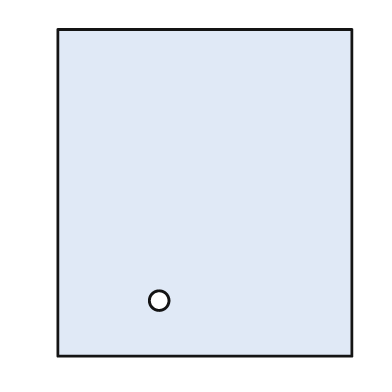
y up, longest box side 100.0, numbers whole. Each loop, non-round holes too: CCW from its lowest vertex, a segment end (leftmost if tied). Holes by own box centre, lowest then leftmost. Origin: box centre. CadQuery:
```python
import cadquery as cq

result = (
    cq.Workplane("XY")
    .moveTo(-45.0, -50.0)
    .lineTo(45.0, -50.0)
    .lineTo(45.0, 50.0)
    .lineTo(-45.0, 50.0)
    .close()
    .moveTo(-14.0, -33.0)
    .circle(3.0)
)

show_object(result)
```